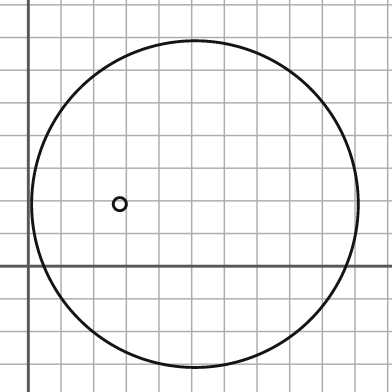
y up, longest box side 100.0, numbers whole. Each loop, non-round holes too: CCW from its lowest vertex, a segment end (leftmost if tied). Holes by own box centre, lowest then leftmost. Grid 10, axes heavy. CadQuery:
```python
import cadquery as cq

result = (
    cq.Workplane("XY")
    .moveTo(51.0, 19.0)
    .circle(50.0)
    .moveTo(28.0, 19.0)
    .circle(2.0)
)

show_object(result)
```